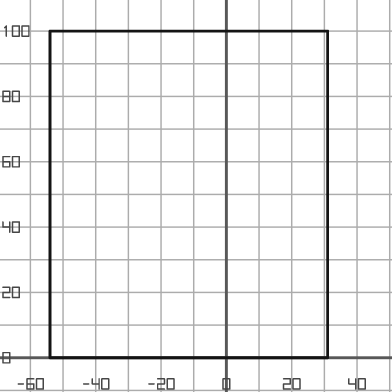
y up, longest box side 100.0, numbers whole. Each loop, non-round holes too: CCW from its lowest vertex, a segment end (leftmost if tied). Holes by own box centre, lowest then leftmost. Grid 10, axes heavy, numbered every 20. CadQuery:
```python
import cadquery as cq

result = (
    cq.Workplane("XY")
    .moveTo(-54.0, 0.0)
    .lineTo(31.0, 0.0)
    .lineTo(31.0, 100.0)
    .lineTo(-54.0, 100.0)
    .close()
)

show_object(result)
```